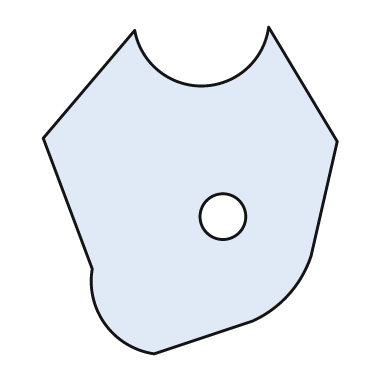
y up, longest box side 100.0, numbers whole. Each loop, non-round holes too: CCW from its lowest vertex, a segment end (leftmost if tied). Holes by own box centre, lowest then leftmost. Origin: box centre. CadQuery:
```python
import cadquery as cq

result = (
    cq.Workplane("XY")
    .moveTo(-11.0, -50.0)
    .lineTo(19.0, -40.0)
    .threePointArc((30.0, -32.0), (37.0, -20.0))
    .lineTo(45.0, 15.0)
    .lineTo(24.0, 50.0)
    .threePointArc((4.0, 32.0), (-17.0, 49.0))
    .lineTo(-45.0, 16.0)
    .lineTo(-30.0, -24.0)
    .threePointArc((-26.0, -41.0), (-11.0, -50.0))
    .close()
    .moveTo(10.0, -8.0)
    .circle(7.0)
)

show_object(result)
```